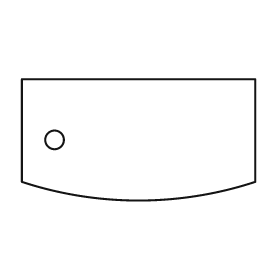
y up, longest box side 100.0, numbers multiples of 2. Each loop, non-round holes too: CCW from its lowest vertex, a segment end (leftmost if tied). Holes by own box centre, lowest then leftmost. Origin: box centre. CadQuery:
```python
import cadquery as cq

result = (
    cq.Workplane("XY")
    .moveTo(-50.0, -18.0)
    .threePointArc((0.0, -26.0), (50.0, -18.0))
    .lineTo(50.0, 26.0)
    .lineTo(-50.0, 26.0)
    .close()
    .moveTo(-36.0, 0.0)
    .circle(4.0)
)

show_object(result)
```